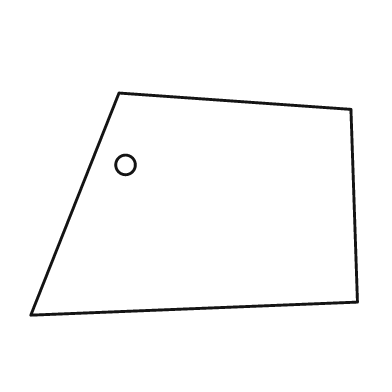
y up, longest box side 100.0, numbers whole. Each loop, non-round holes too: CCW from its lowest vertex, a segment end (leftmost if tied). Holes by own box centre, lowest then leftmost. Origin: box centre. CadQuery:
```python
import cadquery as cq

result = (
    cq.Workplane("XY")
    .moveTo(-50.0, -34.0)
    .lineTo(50.0, -30.0)
    .lineTo(48.0, 29.0)
    .lineTo(-23.0, 34.0)
    .close()
    .moveTo(-21.0, 12.0)
    .circle(3.0)
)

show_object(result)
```